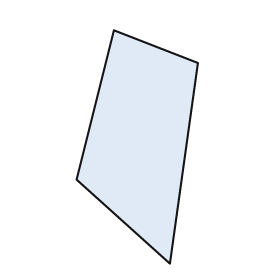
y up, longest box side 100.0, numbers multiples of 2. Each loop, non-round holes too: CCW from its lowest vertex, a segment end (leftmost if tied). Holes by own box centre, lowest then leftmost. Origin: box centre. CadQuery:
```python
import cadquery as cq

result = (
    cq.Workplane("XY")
    .moveTo(14.0, -50.0)
    .lineTo(26.0, 36.0)
    .lineTo(-10.0, 50.0)
    .lineTo(-26.0, -14.0)
    .close()
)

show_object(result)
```